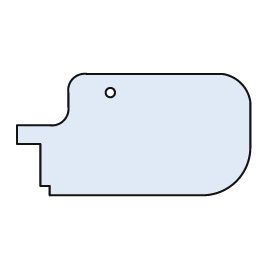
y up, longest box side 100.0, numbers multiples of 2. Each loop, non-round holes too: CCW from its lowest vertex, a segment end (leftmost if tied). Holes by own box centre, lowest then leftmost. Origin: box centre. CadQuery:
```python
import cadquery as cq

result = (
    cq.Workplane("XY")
    .moveTo(-36.0, -26.0)
    .lineTo(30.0, -26.0)
    .threePointArc((44.0, -20.0), (50.0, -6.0))
    .lineTo(50.0, 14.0)
    .threePointArc((46.0, 22.0), (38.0, 26.0))
    .lineTo(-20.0, 26.0)
    .threePointArc((-26.0, 24.0), (-28.0, 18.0))
    .lineTo(-28.0, 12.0)
    .threePointArc((-30.0, 6.0), (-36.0, 4.0))
    .lineTo(-50.0, 4.0)
    .lineTo(-50.0, -4.0)
    .lineTo(-40.0, -4.0)
    .lineTo(-40.0, -22.0)
    .lineTo(-36.0, -22.0)
    .close()
    .moveTo(-10.0, 18.0)
    .circle(2.0)
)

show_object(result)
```